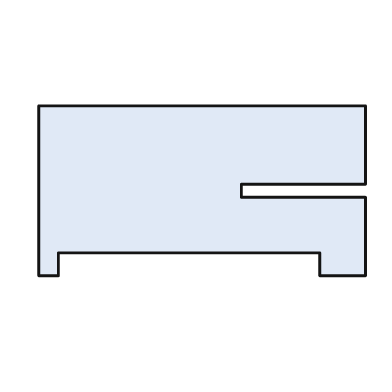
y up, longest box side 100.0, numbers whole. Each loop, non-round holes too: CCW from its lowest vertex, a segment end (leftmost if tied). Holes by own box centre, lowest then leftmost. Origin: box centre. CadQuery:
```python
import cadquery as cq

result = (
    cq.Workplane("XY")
    .moveTo(-50.0, -26.0)
    .lineTo(-44.0, -26.0)
    .lineTo(-44.0, -19.0)
    .lineTo(36.0, -19.0)
    .lineTo(36.0, -26.0)
    .lineTo(50.0, -26.0)
    .lineTo(50.0, -2.0)
    .lineTo(12.0, -2.0)
    .lineTo(12.0, 2.0)
    .lineTo(50.0, 2.0)
    .lineTo(50.0, 26.0)
    .lineTo(-50.0, 26.0)
    .close()
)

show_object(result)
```